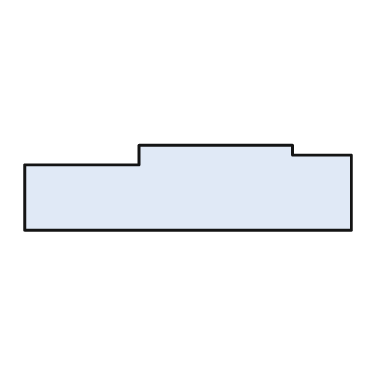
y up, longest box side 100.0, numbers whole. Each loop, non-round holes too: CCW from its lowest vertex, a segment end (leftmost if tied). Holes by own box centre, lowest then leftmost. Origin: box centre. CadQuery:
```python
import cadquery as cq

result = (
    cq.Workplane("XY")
    .moveTo(-50.0, -13.0)
    .lineTo(50.0, -13.0)
    .lineTo(50.0, 10.0)
    .lineTo(32.0, 10.0)
    .lineTo(32.0, 13.0)
    .lineTo(-15.0, 13.0)
    .lineTo(-15.0, 7.0)
    .lineTo(-50.0, 7.0)
    .close()
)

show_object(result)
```